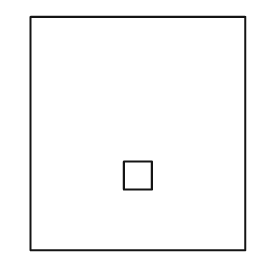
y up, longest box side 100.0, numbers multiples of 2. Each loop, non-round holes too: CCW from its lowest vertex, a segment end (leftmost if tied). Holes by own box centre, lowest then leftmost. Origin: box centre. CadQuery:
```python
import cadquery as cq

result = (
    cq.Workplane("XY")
    .moveTo(-46.0, -50.0)
    .lineTo(46.0, -50.0)
    .lineTo(46.0, 50.0)
    .lineTo(-46.0, 50.0)
    .close()
    .moveTo(-6.0, -24.0)
    .lineTo(6.0, -24.0)
    .lineTo(6.0, -12.0)
    .lineTo(-6.0, -12.0)
    .close()
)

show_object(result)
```